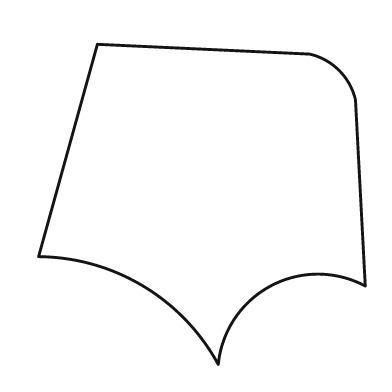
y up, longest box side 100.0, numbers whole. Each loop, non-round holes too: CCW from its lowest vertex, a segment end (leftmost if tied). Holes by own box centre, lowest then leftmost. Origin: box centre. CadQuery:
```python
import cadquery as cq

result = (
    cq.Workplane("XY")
    .moveTo(5.0, -49.0)
    .threePointArc((21.0, -25.0), (50.0, -25.0))
    .lineTo(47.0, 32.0)
    .threePointArc((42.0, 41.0), (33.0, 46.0))
    .lineTo(-32.0, 49.0)
    .lineTo(-50.0, -16.0)
    .threePointArc((-18.0, -25.0), (5.0, -49.0))
    .close()
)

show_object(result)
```